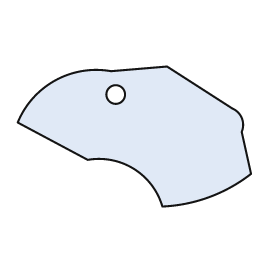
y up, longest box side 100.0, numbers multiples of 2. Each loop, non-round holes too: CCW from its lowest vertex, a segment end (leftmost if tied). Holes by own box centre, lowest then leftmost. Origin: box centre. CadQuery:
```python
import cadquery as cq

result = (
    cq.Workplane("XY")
    .moveTo(12.0, -30.0)
    .threePointArc((32.0, -26.0), (50.0, -16.0))
    .lineTo(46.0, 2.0)
    .threePointArc((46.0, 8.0), (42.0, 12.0))
    .lineTo(14.0, 30.0)
    .lineTo(-10.0, 28.0)
    .threePointArc((-34.0, 24.0), (-50.0, 6.0))
    .lineTo(-20.0, -10.0)
    .threePointArc((0.0, -14.0), (12.0, -30.0))
    .close()
    .moveTo(-8.0, 18.0)
    .circle(4.0)
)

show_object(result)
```